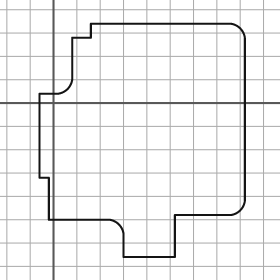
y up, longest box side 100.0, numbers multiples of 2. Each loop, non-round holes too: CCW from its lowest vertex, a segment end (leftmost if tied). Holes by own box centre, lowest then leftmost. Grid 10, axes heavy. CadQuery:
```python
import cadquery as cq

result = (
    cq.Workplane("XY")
    .moveTo(30.0, -66.0)
    .lineTo(52.0, -66.0)
    .lineTo(52.0, -48.0)
    .lineTo(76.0, -48.0)
    .threePointArc((80.0, -46.0), (82.0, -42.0))
    .lineTo(82.0, 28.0)
    .threePointArc((80.0, 32.0), (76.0, 34.0))
    .lineTo(16.0, 34.0)
    .lineTo(16.0, 28.0)
    .lineTo(8.0, 28.0)
    .lineTo(8.0, 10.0)
    .threePointArc((6.0, 6.0), (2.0, 4.0))
    .lineTo(-6.0, 4.0)
    .lineTo(-6.0, -32.0)
    .lineTo(-2.0, -32.0)
    .lineTo(-2.0, -50.0)
    .lineTo(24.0, -50.0)
    .threePointArc((28.0, -52.0), (30.0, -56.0))
    .close()
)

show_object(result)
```